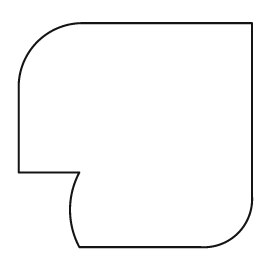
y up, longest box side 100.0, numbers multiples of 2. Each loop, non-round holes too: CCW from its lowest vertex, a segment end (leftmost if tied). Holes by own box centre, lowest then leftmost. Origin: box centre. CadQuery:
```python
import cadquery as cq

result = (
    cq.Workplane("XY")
    .moveTo(-24.0, -48.0)
    .lineTo(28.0, -48.0)
    .threePointArc((44.0, -42.0), (50.0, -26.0))
    .lineTo(50.0, 48.0)
    .lineTo(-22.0, 48.0)
    .threePointArc((-42.0, 40.0), (-50.0, 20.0))
    .lineTo(-50.0, -16.0)
    .lineTo(-24.0, -16.0)
    .threePointArc((-28.0, -32.0), (-24.0, -48.0))
    .close()
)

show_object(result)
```